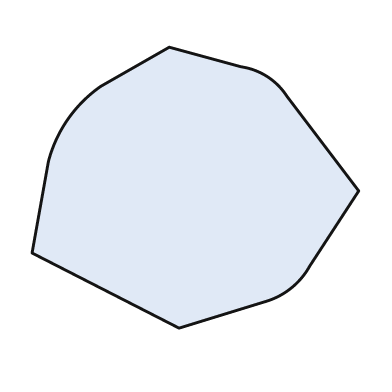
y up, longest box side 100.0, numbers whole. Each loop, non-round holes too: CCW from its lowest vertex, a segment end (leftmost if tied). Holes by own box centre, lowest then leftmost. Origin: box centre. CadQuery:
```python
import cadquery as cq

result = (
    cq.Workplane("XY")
    .moveTo(-5.0, -43.0)
    .lineTo(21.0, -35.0)
    .threePointArc((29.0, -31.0), (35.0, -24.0))
    .lineTo(50.0, -1.0)
    .lineTo(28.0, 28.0)
    .threePointArc((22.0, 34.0), (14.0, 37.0))
    .lineTo(-8.0, 43.0)
    .lineTo(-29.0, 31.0)
    .threePointArc((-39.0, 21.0), (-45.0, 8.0))
    .lineTo(-50.0, -20.0)
    .close()
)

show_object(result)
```